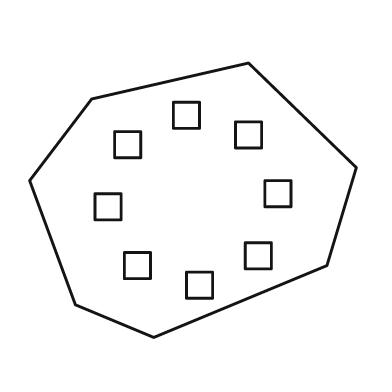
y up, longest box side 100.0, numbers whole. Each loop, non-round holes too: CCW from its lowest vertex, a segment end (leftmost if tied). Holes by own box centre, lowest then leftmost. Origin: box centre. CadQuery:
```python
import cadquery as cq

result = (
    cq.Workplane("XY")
    .moveTo(-12.0, -42.0)
    .lineTo(41.0, -20.0)
    .lineTo(50.0, 10.0)
    .lineTo(17.0, 42.0)
    .lineTo(-31.0, 31.0)
    .lineTo(-50.0, 6.0)
    .lineTo(-36.0, -32.0)
    .close()
    .moveTo(-2.0, -30.0)
    .lineTo(6.0, -30.0)
    .lineTo(6.0, -22.0)
    .lineTo(-2.0, -22.0)
    .close()
    .moveTo(-21.0, -24.0)
    .lineTo(-13.0, -24.0)
    .lineTo(-13.0, -16.0)
    .lineTo(-21.0, -16.0)
    .close()
    .moveTo(16.0, -21.0)
    .lineTo(24.0, -21.0)
    .lineTo(24.0, -13.0)
    .lineTo(16.0, -13.0)
    .close()
    .moveTo(-30.0, -6.0)
    .lineTo(-22.0, -6.0)
    .lineTo(-22.0, 2.0)
    .lineTo(-30.0, 2.0)
    .close()
    .moveTo(22.0, -2.0)
    .lineTo(30.0, -2.0)
    .lineTo(30.0, 6.0)
    .lineTo(22.0, 6.0)
    .close()
    .moveTo(-24.0, 13.0)
    .lineTo(-16.0, 13.0)
    .lineTo(-16.0, 21.0)
    .lineTo(-24.0, 21.0)
    .close()
    .moveTo(13.0, 16.0)
    .lineTo(21.0, 16.0)
    .lineTo(21.0, 24.0)
    .lineTo(13.0, 24.0)
    .close()
    .moveTo(-6.0, 22.0)
    .lineTo(2.0, 22.0)
    .lineTo(2.0, 30.0)
    .lineTo(-6.0, 30.0)
    .close()
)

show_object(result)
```